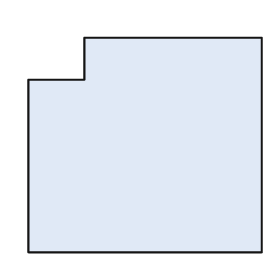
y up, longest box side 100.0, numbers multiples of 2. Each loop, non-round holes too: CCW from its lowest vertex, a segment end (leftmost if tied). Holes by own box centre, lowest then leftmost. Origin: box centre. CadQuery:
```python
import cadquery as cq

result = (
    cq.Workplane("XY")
    .moveTo(-50.0, -46.0)
    .lineTo(50.0, -46.0)
    .lineTo(50.0, 46.0)
    .lineTo(-26.0, 46.0)
    .lineTo(-26.0, 28.0)
    .lineTo(-50.0, 28.0)
    .close()
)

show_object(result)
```